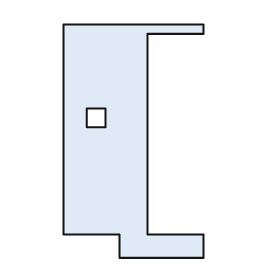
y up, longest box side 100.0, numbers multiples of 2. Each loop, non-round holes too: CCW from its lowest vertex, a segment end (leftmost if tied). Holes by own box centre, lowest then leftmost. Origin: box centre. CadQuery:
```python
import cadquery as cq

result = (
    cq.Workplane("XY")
    .moveTo(-6.0, -50.0)
    .lineTo(30.0, -50.0)
    .lineTo(30.0, -40.0)
    .lineTo(6.0, -40.0)
    .lineTo(6.0, 46.0)
    .lineTo(30.0, 46.0)
    .lineTo(30.0, 50.0)
    .lineTo(-30.0, 50.0)
    .lineTo(-30.0, -40.0)
    .lineTo(-6.0, -40.0)
    .close()
    .moveTo(-20.0, 6.0)
    .lineTo(-12.0, 6.0)
    .lineTo(-12.0, 14.0)
    .lineTo(-20.0, 14.0)
    .close()
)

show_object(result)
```